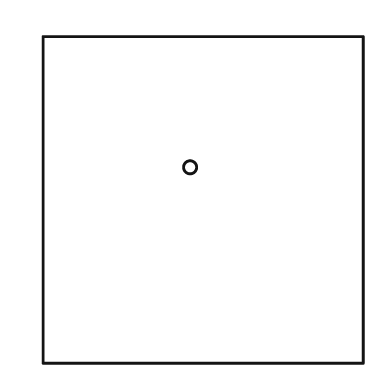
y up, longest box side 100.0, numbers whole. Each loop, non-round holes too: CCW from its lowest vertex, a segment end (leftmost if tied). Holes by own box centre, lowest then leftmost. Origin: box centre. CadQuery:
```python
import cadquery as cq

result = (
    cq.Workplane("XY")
    .moveTo(-49.0, -50.0)
    .lineTo(49.0, -50.0)
    .lineTo(49.0, 50.0)
    .lineTo(-49.0, 50.0)
    .close()
    .moveTo(-4.0, 10.0)
    .circle(2.0)
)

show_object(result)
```